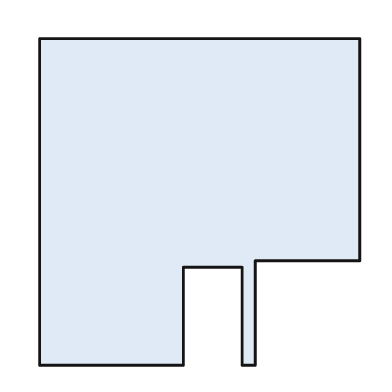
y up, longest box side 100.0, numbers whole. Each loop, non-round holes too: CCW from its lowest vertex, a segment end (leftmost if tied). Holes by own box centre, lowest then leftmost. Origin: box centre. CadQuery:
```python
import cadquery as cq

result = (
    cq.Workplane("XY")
    .moveTo(-49.0, -50.0)
    .lineTo(-5.0, -50.0)
    .lineTo(-5.0, -20.0)
    .lineTo(13.0, -20.0)
    .lineTo(13.0, -50.0)
    .lineTo(17.0, -50.0)
    .lineTo(17.0, -18.0)
    .lineTo(49.0, -18.0)
    .lineTo(49.0, 50.0)
    .lineTo(-49.0, 50.0)
    .close()
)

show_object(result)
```